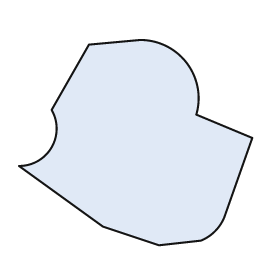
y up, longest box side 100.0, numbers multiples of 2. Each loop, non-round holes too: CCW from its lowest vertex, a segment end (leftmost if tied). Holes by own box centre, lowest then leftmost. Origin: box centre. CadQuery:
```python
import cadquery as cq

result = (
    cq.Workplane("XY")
    .moveTo(10.0, -44.0)
    .lineTo(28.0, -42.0)
    .threePointArc((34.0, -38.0), (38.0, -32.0))
    .lineTo(50.0, 2.0)
    .lineTo(26.0, 12.0)
    .threePointArc((22.0, 34.0), (2.0, 44.0))
    .lineTo(-20.0, 42.0)
    .lineTo(-36.0, 14.0)
    .threePointArc((-36.0, -2.0), (-50.0, -10.0))
    .lineTo(-14.0, -36.0)
    .close()
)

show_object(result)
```